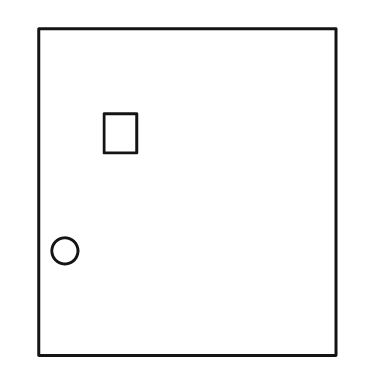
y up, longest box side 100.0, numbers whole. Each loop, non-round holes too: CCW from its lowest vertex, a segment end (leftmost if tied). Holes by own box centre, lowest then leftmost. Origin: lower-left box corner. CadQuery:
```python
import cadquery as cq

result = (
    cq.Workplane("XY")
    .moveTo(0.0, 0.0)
    .lineTo(91.0, 0.0)
    .lineTo(91.0, 100.0)
    .lineTo(0.0, 100.0)
    .close()
    .moveTo(8.0, 32.0)
    .circle(4.0)
    .moveTo(20.0, 62.0)
    .lineTo(30.0, 62.0)
    .lineTo(30.0, 74.0)
    .lineTo(20.0, 74.0)
    .close()
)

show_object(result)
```